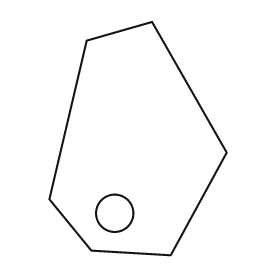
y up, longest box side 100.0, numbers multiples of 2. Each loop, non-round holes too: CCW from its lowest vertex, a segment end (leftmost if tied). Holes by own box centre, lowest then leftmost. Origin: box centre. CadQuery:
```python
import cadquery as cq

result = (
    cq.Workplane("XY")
    .moveTo(14.0, -50.0)
    .lineTo(38.0, -6.0)
    .lineTo(6.0, 50.0)
    .lineTo(-22.0, 42.0)
    .lineTo(-38.0, -26.0)
    .lineTo(-20.0, -48.0)
    .close()
    .moveTo(-10.0, -32.0)
    .circle(8.0)
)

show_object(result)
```